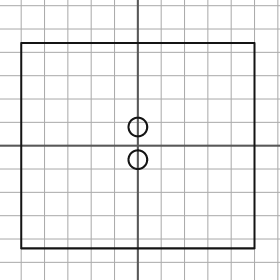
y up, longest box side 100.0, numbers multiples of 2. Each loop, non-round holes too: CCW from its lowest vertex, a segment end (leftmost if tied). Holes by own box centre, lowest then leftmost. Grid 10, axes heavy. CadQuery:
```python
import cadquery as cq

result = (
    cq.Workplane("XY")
    .moveTo(-50.0, -44.0)
    .lineTo(50.0, -44.0)
    .lineTo(50.0, 44.0)
    .lineTo(-50.0, 44.0)
    .close()
    .moveTo(0.0, -6.0)
    .circle(4.0)
    .moveTo(0.0, 8.0)
    .circle(4.0)
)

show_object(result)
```